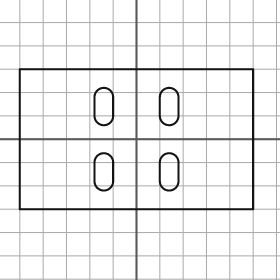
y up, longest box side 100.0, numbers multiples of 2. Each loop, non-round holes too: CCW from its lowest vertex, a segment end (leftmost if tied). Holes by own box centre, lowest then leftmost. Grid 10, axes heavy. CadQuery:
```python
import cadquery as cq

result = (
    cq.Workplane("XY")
    .moveTo(-50.0, -30.0)
    .lineTo(50.0, -30.0)
    .lineTo(50.0, 30.0)
    .lineTo(-50.0, 30.0)
    .close()
    .moveTo(-18.0, -18.0)
    .threePointArc((-14.0, -22.0), (-10.0, -18.0))
    .lineTo(-10.0, -10.0)
    .threePointArc((-14.0, -6.0), (-18.0, -10.0))
    .close()
    .moveTo(10.0, -18.0)
    .threePointArc((14.0, -22.0), (18.0, -18.0))
    .lineTo(18.0, -10.0)
    .threePointArc((14.0, -6.0), (10.0, -10.0))
    .close()
    .moveTo(-18.0, 10.0)
    .threePointArc((-14.0, 6.0), (-10.0, 10.0))
    .lineTo(-10.0, 18.0)
    .threePointArc((-14.0, 22.0), (-18.0, 18.0))
    .close()
    .moveTo(10.0, 10.0)
    .threePointArc((14.0, 6.0), (18.0, 10.0))
    .lineTo(18.0, 18.0)
    .threePointArc((14.0, 22.0), (10.0, 18.0))
    .close()
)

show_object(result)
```